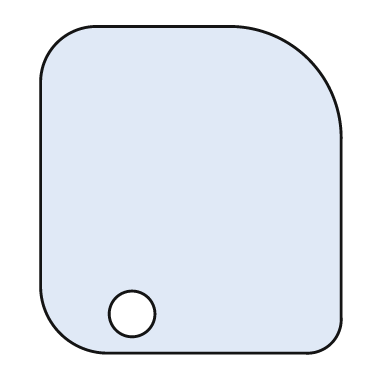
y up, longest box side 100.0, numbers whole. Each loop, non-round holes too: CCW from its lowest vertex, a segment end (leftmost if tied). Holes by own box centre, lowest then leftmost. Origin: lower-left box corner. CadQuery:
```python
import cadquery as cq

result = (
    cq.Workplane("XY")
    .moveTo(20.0, 0.0)
    .lineTo(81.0, 0.0)
    .threePointArc((89.0, 3.0), (92.0, 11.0))
    .lineTo(92.0, 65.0)
    .threePointArc((82.0, 90.0), (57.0, 100.0))
    .lineTo(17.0, 100.0)
    .threePointArc((5.0, 95.0), (0.0, 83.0))
    .lineTo(0.0, 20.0)
    .threePointArc((6.0, 6.0), (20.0, 0.0))
    .close()
    .moveTo(28.0, 12.0)
    .circle(7.0)
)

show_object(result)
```